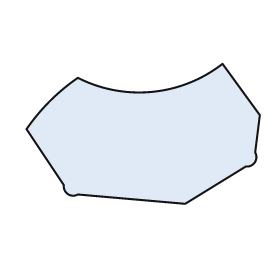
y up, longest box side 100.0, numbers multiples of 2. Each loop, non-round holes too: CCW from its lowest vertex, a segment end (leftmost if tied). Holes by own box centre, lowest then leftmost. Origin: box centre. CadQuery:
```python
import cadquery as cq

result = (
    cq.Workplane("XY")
    .moveTo(18.0, -30.0)
    .lineTo(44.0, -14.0)
    .threePointArc((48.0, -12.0), (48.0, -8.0))
    .lineTo(50.0, 8.0)
    .lineTo(34.0, 30.0)
    .threePointArc((4.0, 18.0), (-28.0, 24.0))
    .threePointArc((-40.0, 14.0), (-50.0, 2.0))
    .lineTo(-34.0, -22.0)
    .threePointArc((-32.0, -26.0), (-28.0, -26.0))
    .close()
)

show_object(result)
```